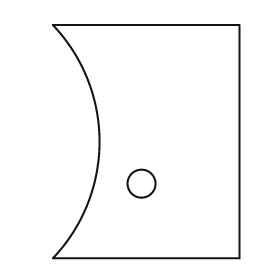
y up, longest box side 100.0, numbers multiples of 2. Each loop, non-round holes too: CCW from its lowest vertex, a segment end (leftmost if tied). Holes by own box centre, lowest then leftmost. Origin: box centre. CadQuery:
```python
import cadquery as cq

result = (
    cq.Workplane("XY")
    .moveTo(-40.0, -50.0)
    .lineTo(40.0, -50.0)
    .lineTo(40.0, 50.0)
    .lineTo(-40.0, 50.0)
    .threePointArc((-20.0, 0.0), (-40.0, -50.0))
    .close()
    .moveTo(-2.0, -18.0)
    .circle(6.0)
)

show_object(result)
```